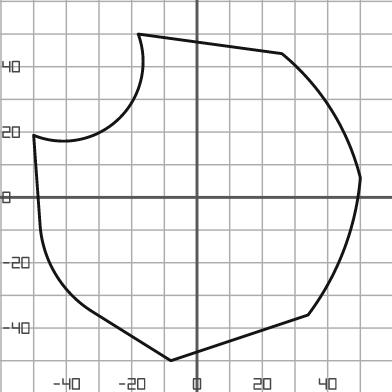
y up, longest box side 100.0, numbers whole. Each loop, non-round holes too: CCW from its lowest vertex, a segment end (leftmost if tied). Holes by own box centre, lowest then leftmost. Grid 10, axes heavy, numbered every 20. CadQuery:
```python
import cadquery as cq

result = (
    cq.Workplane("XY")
    .moveTo(-8.0, -50.0)
    .lineTo(34.0, -36.0)
    .threePointArc((45.0, -16.0), (50.0, 6.0))
    .threePointArc((41.0, 27.0), (26.0, 44.0))
    .lineTo(-18.0, 50.0)
    .threePointArc((-24.0, 24.0), (-50.0, 19.0))
    .lineTo(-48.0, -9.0)
    .threePointArc((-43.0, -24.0), (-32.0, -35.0))
    .close()
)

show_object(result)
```